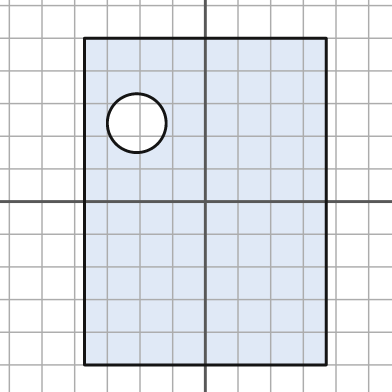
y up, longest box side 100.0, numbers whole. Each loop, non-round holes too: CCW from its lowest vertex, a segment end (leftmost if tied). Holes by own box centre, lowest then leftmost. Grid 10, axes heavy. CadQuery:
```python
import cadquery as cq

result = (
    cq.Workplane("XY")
    .moveTo(-37.0, -50.0)
    .lineTo(37.0, -50.0)
    .lineTo(37.0, 50.0)
    .lineTo(-37.0, 50.0)
    .close()
    .moveTo(-21.0, 24.0)
    .circle(9.0)
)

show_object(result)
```